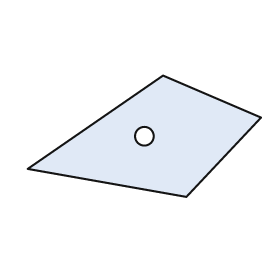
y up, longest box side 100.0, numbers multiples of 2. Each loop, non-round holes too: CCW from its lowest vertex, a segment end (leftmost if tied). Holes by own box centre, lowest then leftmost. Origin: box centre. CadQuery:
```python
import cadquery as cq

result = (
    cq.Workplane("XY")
    .moveTo(18.0, -26.0)
    .lineTo(50.0, 8.0)
    .lineTo(8.0, 26.0)
    .lineTo(-50.0, -14.0)
    .close()
    .moveTo(0.0, 0.0)
    .circle(4.0)
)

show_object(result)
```